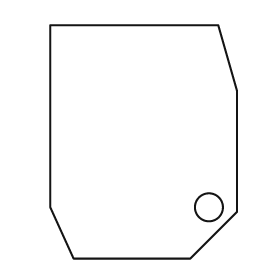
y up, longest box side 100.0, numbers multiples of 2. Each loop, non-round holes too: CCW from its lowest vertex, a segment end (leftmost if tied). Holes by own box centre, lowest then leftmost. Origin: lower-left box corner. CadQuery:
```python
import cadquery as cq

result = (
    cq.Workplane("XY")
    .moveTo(10.0, 0.0)
    .lineTo(60.0, 0.0)
    .lineTo(80.0, 20.0)
    .lineTo(80.0, 72.0)
    .lineTo(72.0, 100.0)
    .lineTo(0.0, 100.0)
    .lineTo(0.0, 22.0)
    .close()
    .moveTo(68.0, 22.0)
    .circle(6.0)
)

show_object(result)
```